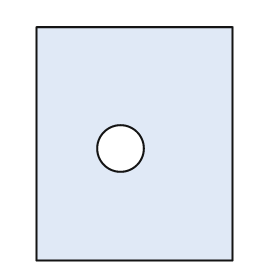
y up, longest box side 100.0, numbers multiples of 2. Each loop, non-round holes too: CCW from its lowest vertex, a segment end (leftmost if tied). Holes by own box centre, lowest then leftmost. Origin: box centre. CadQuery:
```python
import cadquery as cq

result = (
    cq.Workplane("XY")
    .moveTo(-42.0, -50.0)
    .lineTo(42.0, -50.0)
    .lineTo(42.0, 50.0)
    .lineTo(-42.0, 50.0)
    .close()
    .moveTo(-6.0, -2.0)
    .circle(10.0)
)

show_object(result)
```